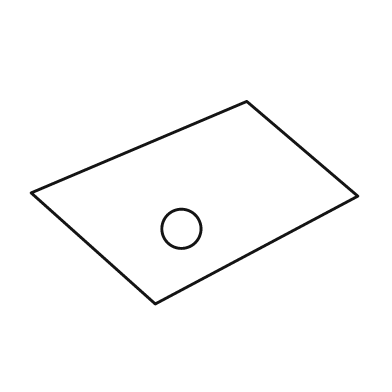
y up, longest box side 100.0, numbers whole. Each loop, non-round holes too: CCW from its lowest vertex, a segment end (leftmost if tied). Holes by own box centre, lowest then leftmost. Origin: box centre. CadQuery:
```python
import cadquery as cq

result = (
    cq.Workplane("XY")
    .moveTo(-12.0, -31.0)
    .lineTo(50.0, 2.0)
    .lineTo(16.0, 31.0)
    .lineTo(-50.0, 3.0)
    .close()
    .moveTo(-4.0, -8.0)
    .circle(6.0)
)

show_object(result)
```